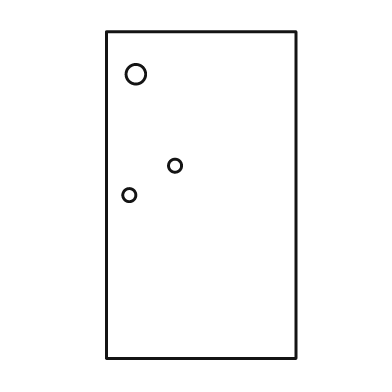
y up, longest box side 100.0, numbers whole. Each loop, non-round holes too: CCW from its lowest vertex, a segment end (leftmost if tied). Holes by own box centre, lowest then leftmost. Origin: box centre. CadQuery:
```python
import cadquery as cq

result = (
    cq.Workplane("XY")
    .moveTo(-29.0, -50.0)
    .lineTo(29.0, -50.0)
    .lineTo(29.0, 50.0)
    .lineTo(-29.0, 50.0)
    .close()
    .moveTo(-22.0, 0.0)
    .circle(2.0)
    .moveTo(-8.0, 9.0)
    .circle(2.0)
    .moveTo(-20.0, 37.0)
    .circle(3.0)
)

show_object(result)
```